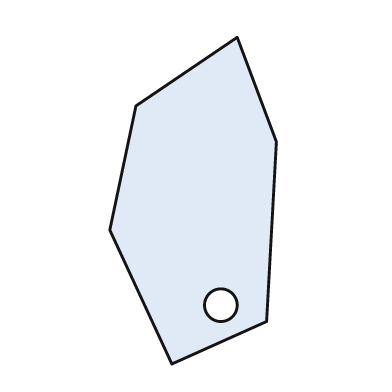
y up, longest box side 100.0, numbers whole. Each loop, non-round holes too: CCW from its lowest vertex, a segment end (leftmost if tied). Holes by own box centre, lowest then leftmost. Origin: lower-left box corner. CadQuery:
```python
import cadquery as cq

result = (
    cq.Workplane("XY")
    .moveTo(19.0, 0.0)
    .lineTo(48.0, 13.0)
    .lineTo(51.0, 68.0)
    .lineTo(39.0, 100.0)
    .lineTo(8.0, 79.0)
    .lineTo(0.0, 41.0)
    .close()
    .moveTo(34.0, 18.0)
    .circle(5.0)
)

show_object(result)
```